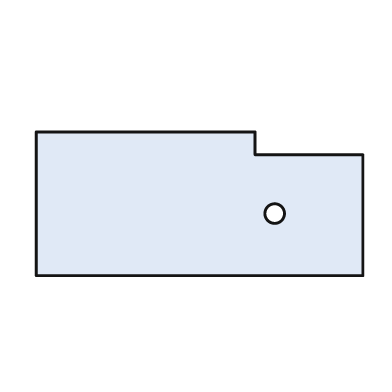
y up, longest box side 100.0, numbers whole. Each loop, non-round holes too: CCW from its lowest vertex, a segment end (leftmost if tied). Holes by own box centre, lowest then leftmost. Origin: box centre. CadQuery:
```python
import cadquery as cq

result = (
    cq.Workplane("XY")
    .moveTo(-50.0, -22.0)
    .lineTo(50.0, -22.0)
    .lineTo(50.0, 15.0)
    .lineTo(17.0, 15.0)
    .lineTo(17.0, 22.0)
    .lineTo(-50.0, 22.0)
    .close()
    .moveTo(23.0, -3.0)
    .circle(3.0)
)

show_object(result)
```